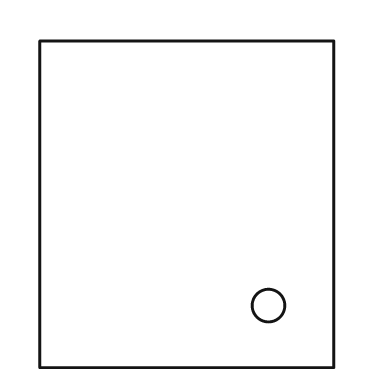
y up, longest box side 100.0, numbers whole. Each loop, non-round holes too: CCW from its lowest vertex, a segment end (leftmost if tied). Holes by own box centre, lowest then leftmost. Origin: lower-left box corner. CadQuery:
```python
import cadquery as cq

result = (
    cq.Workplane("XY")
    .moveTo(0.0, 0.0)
    .lineTo(90.0, 0.0)
    .lineTo(90.0, 100.0)
    .lineTo(0.0, 100.0)
    .close()
    .moveTo(70.0, 19.0)
    .circle(5.0)
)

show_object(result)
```